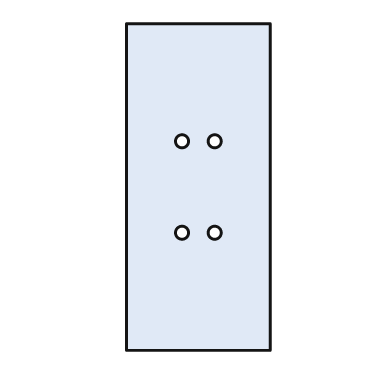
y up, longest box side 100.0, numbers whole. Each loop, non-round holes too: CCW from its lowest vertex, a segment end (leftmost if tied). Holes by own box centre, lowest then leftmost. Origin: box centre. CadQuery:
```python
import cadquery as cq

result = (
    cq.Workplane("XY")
    .moveTo(-22.0, -50.0)
    .lineTo(22.0, -50.0)
    .lineTo(22.0, 50.0)
    .lineTo(-22.0, 50.0)
    .close()
    .moveTo(-5.0, -14.0)
    .circle(2.0)
    .moveTo(5.0, -14.0)
    .circle(2.0)
    .moveTo(-5.0, 14.0)
    .circle(2.0)
    .moveTo(5.0, 14.0)
    .circle(2.0)
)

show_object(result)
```